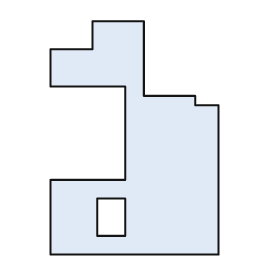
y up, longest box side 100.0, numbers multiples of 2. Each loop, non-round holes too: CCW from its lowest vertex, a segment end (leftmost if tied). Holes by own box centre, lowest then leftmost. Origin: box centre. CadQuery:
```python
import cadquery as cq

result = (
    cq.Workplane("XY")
    .moveTo(-36.0, -50.0)
    .lineTo(36.0, -50.0)
    .lineTo(36.0, 14.0)
    .lineTo(26.0, 14.0)
    .lineTo(26.0, 18.0)
    .lineTo(4.0, 18.0)
    .lineTo(4.0, 50.0)
    .lineTo(-18.0, 50.0)
    .lineTo(-18.0, 38.0)
    .lineTo(-36.0, 38.0)
    .lineTo(-36.0, 22.0)
    .lineTo(-4.0, 22.0)
    .lineTo(-4.0, -18.0)
    .lineTo(-36.0, -18.0)
    .close()
    .moveTo(-16.0, -42.0)
    .lineTo(-4.0, -42.0)
    .lineTo(-4.0, -26.0)
    .lineTo(-16.0, -26.0)
    .close()
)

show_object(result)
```